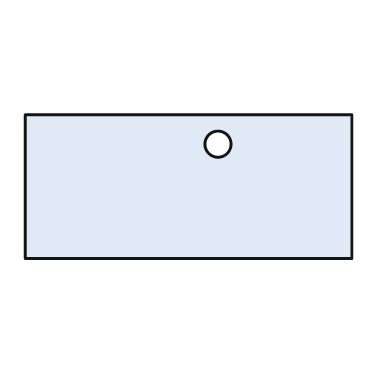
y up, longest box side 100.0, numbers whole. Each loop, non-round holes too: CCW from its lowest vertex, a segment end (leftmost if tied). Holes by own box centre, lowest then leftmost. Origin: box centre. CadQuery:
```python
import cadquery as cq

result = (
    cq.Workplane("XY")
    .moveTo(-50.0, -22.0)
    .lineTo(50.0, -22.0)
    .lineTo(50.0, 22.0)
    .lineTo(-50.0, 22.0)
    .close()
    .moveTo(9.0, 13.0)
    .circle(4.0)
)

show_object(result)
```